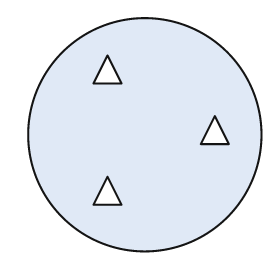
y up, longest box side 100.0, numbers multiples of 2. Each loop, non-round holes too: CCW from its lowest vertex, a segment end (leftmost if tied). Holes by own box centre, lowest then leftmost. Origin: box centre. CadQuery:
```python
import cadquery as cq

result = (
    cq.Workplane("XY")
    .moveTo(0.0, 0.0)
    .circle(50.0)
    .moveTo(-22.0, -30.0)
    .lineTo(-10.0, -30.0)
    .lineTo(-16.0, -18.0)
    .close()
    .moveTo(24.0, -4.0)
    .lineTo(36.0, -4.0)
    .lineTo(30.0, 8.0)
    .close()
    .moveTo(-22.0, 22.0)
    .lineTo(-10.0, 22.0)
    .lineTo(-16.0, 34.0)
    .close()
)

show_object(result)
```